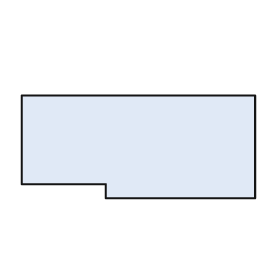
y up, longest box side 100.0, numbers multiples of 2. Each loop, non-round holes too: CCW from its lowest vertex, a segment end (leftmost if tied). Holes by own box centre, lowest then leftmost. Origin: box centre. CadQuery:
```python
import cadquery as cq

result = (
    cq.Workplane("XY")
    .moveTo(-14.0, -22.0)
    .lineTo(50.0, -22.0)
    .lineTo(50.0, 22.0)
    .lineTo(-50.0, 22.0)
    .lineTo(-50.0, -16.0)
    .lineTo(-14.0, -16.0)
    .close()
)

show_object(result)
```